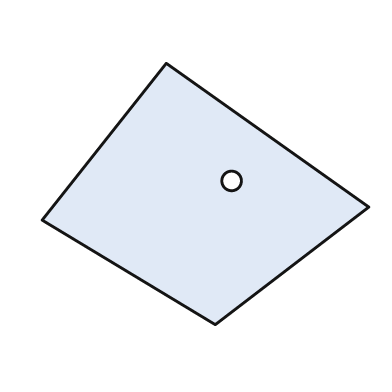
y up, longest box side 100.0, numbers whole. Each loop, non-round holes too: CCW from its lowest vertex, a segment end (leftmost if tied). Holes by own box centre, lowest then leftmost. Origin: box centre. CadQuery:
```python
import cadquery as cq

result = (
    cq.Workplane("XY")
    .moveTo(3.0, -40.0)
    .lineTo(50.0, -4.0)
    .lineTo(-12.0, 40.0)
    .lineTo(-50.0, -8.0)
    .close()
    .moveTo(8.0, 4.0)
    .circle(3.0)
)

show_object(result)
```